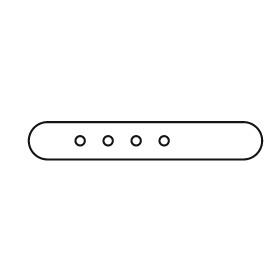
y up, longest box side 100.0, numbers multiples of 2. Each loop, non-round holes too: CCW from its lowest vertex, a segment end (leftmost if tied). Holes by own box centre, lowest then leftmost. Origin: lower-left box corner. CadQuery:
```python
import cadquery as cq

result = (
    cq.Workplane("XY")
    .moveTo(8.0, 0.0)
    .lineTo(92.0, 0.0)
    .threePointArc((100.0, 8.0), (92.0, 16.0))
    .lineTo(8.0, 16.0)
    .threePointArc((0.0, 8.0), (8.0, 0.0))
    .close()
    .moveTo(22.0, 8.0)
    .circle(2.0)
    .moveTo(34.0, 8.0)
    .circle(2.0)
    .moveTo(46.0, 8.0)
    .circle(2.0)
    .moveTo(58.0, 8.0)
    .circle(2.0)
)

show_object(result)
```